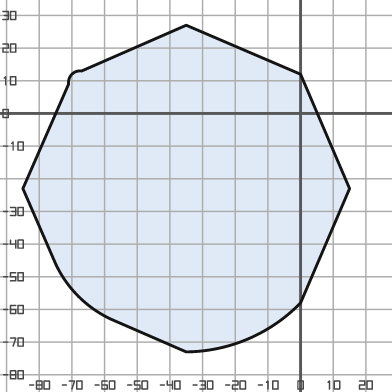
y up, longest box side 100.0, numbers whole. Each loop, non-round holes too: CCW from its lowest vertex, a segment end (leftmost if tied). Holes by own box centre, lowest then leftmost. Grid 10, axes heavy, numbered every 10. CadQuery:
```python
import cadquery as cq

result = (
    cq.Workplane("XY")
    .moveTo(-35.0, -73.0)
    .threePointArc((-16.0, -69.0), (0.0, -58.0))
    .lineTo(15.0, -23.0)
    .lineTo(0.0, 12.0)
    .lineTo(-35.0, 27.0)
    .lineTo(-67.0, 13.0)
    .threePointArc((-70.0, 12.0), (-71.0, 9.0))
    .lineTo(-85.0, -23.0)
    .lineTo(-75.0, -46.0)
    .threePointArc((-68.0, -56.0), (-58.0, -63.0))
    .close()
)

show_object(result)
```